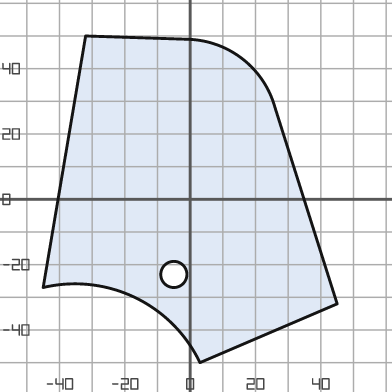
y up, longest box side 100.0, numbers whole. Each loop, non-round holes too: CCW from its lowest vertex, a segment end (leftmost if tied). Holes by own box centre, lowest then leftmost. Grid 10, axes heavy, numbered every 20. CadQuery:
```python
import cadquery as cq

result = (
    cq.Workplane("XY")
    .moveTo(3.0, -50.0)
    .lineTo(45.0, -32.0)
    .lineTo(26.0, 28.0)
    .threePointArc((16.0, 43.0), (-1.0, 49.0))
    .lineTo(-32.0, 50.0)
    .lineTo(-45.0, -27.0)
    .threePointArc((-17.0, -30.0), (3.0, -50.0))
    .close()
    .moveTo(-5.0, -23.0)
    .circle(4.0)
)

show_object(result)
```